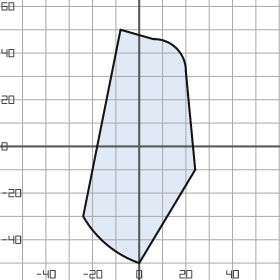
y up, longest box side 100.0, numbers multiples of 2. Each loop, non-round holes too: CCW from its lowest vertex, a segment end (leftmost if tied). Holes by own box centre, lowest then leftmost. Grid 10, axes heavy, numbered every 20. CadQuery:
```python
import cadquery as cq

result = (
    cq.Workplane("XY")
    .moveTo(0.0, -50.0)
    .lineTo(24.0, -10.0)
    .lineTo(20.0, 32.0)
    .threePointArc((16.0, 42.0), (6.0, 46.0))
    .lineTo(-8.0, 50.0)
    .lineTo(-24.0, -30.0)
    .threePointArc((-14.0, -42.0), (0.0, -50.0))
    .close()
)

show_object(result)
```